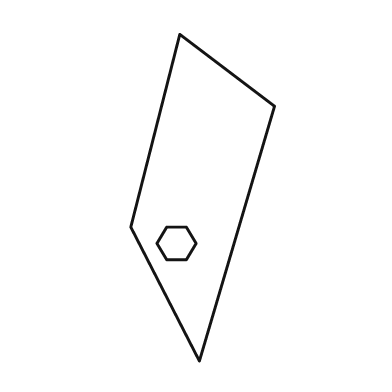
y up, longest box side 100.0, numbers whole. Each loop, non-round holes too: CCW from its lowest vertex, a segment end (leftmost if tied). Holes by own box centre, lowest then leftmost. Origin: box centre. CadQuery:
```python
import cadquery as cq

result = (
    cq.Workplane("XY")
    .moveTo(-1.0, -50.0)
    .lineTo(22.0, 28.0)
    .lineTo(-7.0, 50.0)
    .lineTo(-22.0, -9.0)
    .close()
    .moveTo(-11.0, -19.0)
    .lineTo(-5.0, -19.0)
    .lineTo(-2.0, -14.0)
    .lineTo(-5.0, -9.0)
    .lineTo(-11.0, -9.0)
    .lineTo(-14.0, -14.0)
    .close()
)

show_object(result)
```